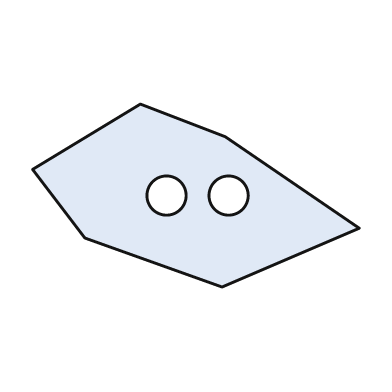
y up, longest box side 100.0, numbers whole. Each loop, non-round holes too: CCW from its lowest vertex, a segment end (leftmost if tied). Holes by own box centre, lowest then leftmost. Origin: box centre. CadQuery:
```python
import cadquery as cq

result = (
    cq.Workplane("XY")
    .moveTo(8.0, -28.0)
    .lineTo(50.0, -10.0)
    .lineTo(9.0, 18.0)
    .lineTo(-17.0, 28.0)
    .lineTo(-50.0, 8.0)
    .lineTo(-34.0, -13.0)
    .close()
    .moveTo(-9.0, 0.0)
    .circle(6.0)
    .moveTo(10.0, 0.0)
    .circle(6.0)
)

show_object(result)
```